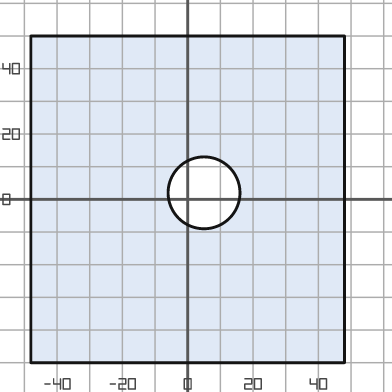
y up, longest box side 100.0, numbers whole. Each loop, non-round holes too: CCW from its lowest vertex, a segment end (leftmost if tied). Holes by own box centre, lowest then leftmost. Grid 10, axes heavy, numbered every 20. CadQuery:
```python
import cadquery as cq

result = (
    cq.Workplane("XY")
    .moveTo(-48.0, -50.0)
    .lineTo(48.0, -50.0)
    .lineTo(48.0, 50.0)
    .lineTo(-48.0, 50.0)
    .close()
    .moveTo(5.0, 2.0)
    .circle(11.0)
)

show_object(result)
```